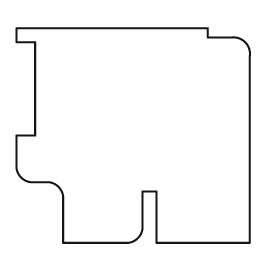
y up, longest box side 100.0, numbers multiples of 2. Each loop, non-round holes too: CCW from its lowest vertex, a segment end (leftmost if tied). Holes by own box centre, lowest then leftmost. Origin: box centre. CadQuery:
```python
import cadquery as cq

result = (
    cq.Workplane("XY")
    .moveTo(-30.0, -46.0)
    .lineTo(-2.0, -46.0)
    .threePointArc((2.0, -44.0), (4.0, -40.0))
    .lineTo(4.0, -24.0)
    .lineTo(10.0, -24.0)
    .lineTo(10.0, -46.0)
    .lineTo(50.0, -46.0)
    .lineTo(50.0, 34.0)
    .threePointArc((48.0, 40.0), (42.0, 42.0))
    .lineTo(32.0, 42.0)
    .lineTo(32.0, 46.0)
    .lineTo(-50.0, 46.0)
    .lineTo(-50.0, 40.0)
    .lineTo(-42.0, 40.0)
    .lineTo(-42.0, 0.0)
    .lineTo(-50.0, 0.0)
    .lineTo(-50.0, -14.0)
    .threePointArc((-48.0, -18.0), (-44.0, -20.0))
    .lineTo(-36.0, -20.0)
    .threePointArc((-32.0, -22.0), (-30.0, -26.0))
    .close()
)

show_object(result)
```